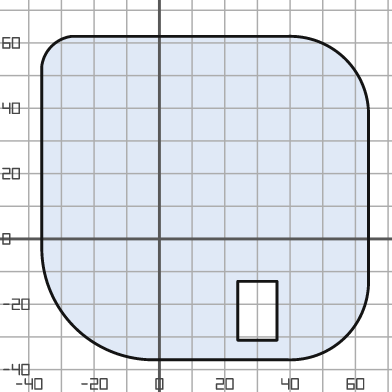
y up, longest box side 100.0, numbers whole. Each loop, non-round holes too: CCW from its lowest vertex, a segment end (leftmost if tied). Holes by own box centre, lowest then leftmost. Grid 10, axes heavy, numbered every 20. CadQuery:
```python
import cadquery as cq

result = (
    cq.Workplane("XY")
    .moveTo(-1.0, -37.0)
    .lineTo(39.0, -37.0)
    .threePointArc((57.0, -30.0), (64.0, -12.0))
    .lineTo(64.0, 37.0)
    .threePointArc((57.0, 55.0), (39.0, 62.0))
    .lineTo(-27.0, 62.0)
    .threePointArc((-33.0, 59.0), (-36.0, 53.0))
    .lineTo(-36.0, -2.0)
    .threePointArc((-26.0, -27.0), (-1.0, -37.0))
    .close()
    .moveTo(24.0, -31.0)
    .lineTo(36.0, -31.0)
    .lineTo(36.0, -13.0)
    .lineTo(24.0, -13.0)
    .close()
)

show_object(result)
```